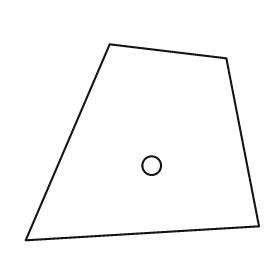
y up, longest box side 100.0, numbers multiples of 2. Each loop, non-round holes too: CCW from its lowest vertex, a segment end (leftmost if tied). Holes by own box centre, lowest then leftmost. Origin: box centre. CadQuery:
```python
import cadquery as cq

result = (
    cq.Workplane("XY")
    .moveTo(-50.0, -42.0)
    .lineTo(50.0, -36.0)
    .lineTo(36.0, 36.0)
    .lineTo(-14.0, 42.0)
    .close()
    .moveTo(4.0, -10.0)
    .circle(4.0)
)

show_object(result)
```